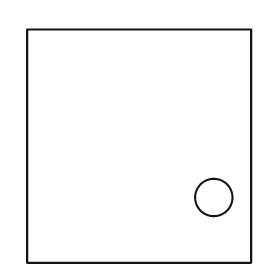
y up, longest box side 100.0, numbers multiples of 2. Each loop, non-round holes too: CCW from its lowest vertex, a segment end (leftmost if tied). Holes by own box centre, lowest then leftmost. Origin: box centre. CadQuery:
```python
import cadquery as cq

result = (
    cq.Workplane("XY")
    .moveTo(-48.0, -50.0)
    .lineTo(48.0, -50.0)
    .lineTo(48.0, 50.0)
    .lineTo(-48.0, 50.0)
    .close()
    .moveTo(32.0, -22.0)
    .circle(8.0)
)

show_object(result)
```